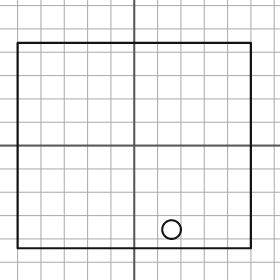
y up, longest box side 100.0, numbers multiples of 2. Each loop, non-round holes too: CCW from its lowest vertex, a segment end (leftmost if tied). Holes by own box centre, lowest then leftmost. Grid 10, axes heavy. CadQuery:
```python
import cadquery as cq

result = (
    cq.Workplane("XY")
    .moveTo(-50.0, -44.0)
    .lineTo(50.0, -44.0)
    .lineTo(50.0, 44.0)
    .lineTo(-50.0, 44.0)
    .close()
    .moveTo(16.0, -36.0)
    .circle(4.0)
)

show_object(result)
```